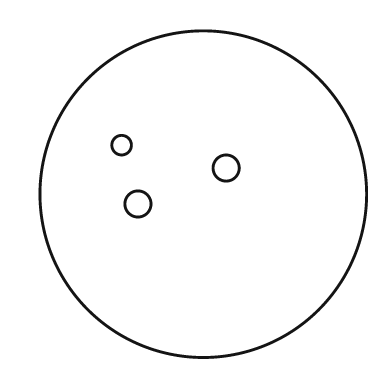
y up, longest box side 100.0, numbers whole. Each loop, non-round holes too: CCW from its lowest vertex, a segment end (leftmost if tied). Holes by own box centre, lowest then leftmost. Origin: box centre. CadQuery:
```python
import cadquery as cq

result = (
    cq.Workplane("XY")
    .moveTo(0.0, 0.0)
    .circle(50.0)
    .moveTo(-20.0, -3.0)
    .circle(4.0)
    .moveTo(7.0, 8.0)
    .circle(4.0)
    .moveTo(-25.0, 15.0)
    .circle(3.0)
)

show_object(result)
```